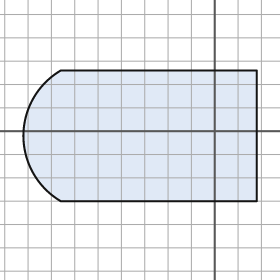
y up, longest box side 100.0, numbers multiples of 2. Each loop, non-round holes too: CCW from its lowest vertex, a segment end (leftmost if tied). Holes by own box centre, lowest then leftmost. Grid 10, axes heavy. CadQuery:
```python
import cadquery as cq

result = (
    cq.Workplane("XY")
    .moveTo(-66.0, -30.0)
    .lineTo(18.0, -30.0)
    .lineTo(18.0, 26.0)
    .lineTo(-66.0, 26.0)
    .threePointArc((-82.0, -2.0), (-66.0, -30.0))
    .close()
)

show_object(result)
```